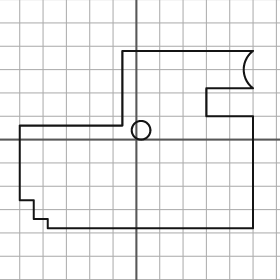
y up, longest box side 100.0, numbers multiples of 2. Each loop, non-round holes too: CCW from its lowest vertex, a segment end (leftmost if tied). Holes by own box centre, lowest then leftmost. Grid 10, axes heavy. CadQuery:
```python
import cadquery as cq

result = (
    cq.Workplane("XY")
    .moveTo(-38.0, -38.0)
    .lineTo(50.0, -38.0)
    .lineTo(50.0, 10.0)
    .lineTo(30.0, 10.0)
    .lineTo(30.0, 22.0)
    .lineTo(50.0, 22.0)
    .threePointArc((46.0, 30.0), (50.0, 38.0))
    .lineTo(-6.0, 38.0)
    .lineTo(-6.0, 6.0)
    .lineTo(-50.0, 6.0)
    .lineTo(-50.0, -26.0)
    .lineTo(-44.0, -26.0)
    .lineTo(-44.0, -34.0)
    .lineTo(-38.0, -34.0)
    .close()
    .moveTo(2.0, 4.0)
    .circle(4.0)
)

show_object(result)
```